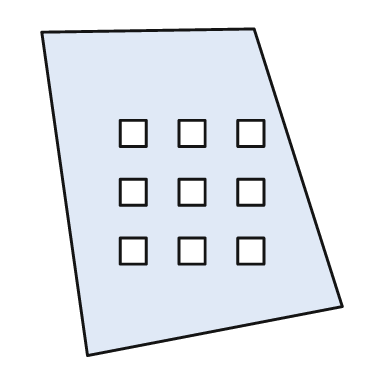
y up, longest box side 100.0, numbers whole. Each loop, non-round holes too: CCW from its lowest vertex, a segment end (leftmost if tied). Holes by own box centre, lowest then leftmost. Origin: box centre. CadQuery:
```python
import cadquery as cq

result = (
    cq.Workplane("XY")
    .moveTo(-32.0, -50.0)
    .lineTo(46.0, -35.0)
    .lineTo(19.0, 50.0)
    .lineTo(-46.0, 49.0)
    .close()
    .moveTo(-22.0, -22.0)
    .lineTo(-14.0, -22.0)
    .lineTo(-14.0, -14.0)
    .lineTo(-22.0, -14.0)
    .close()
    .moveTo(-4.0, -22.0)
    .lineTo(4.0, -22.0)
    .lineTo(4.0, -14.0)
    .lineTo(-4.0, -14.0)
    .close()
    .moveTo(14.0, -22.0)
    .lineTo(22.0, -22.0)
    .lineTo(22.0, -14.0)
    .lineTo(14.0, -14.0)
    .close()
    .moveTo(-22.0, -4.0)
    .lineTo(-14.0, -4.0)
    .lineTo(-14.0, 4.0)
    .lineTo(-22.0, 4.0)
    .close()
    .moveTo(-4.0, -4.0)
    .lineTo(4.0, -4.0)
    .lineTo(4.0, 4.0)
    .lineTo(-4.0, 4.0)
    .close()
    .moveTo(14.0, -4.0)
    .lineTo(22.0, -4.0)
    .lineTo(22.0, 4.0)
    .lineTo(14.0, 4.0)
    .close()
    .moveTo(-22.0, 14.0)
    .lineTo(-14.0, 14.0)
    .lineTo(-14.0, 22.0)
    .lineTo(-22.0, 22.0)
    .close()
    .moveTo(-4.0, 14.0)
    .lineTo(4.0, 14.0)
    .lineTo(4.0, 22.0)
    .lineTo(-4.0, 22.0)
    .close()
    .moveTo(14.0, 14.0)
    .lineTo(22.0, 14.0)
    .lineTo(22.0, 22.0)
    .lineTo(14.0, 22.0)
    .close()
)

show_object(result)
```